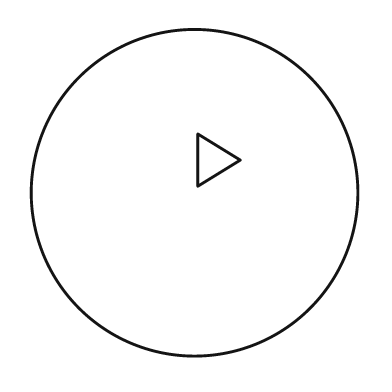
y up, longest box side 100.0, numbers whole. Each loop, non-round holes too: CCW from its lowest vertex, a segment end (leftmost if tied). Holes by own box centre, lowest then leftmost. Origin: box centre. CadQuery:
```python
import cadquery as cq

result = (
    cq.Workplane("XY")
    .moveTo(0.0, 0.0)
    .circle(50.0)
    .moveTo(1.0, 2.0)
    .lineTo(14.0, 10.0)
    .lineTo(1.0, 18.0)
    .close()
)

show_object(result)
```